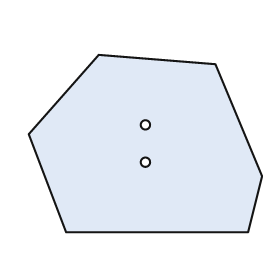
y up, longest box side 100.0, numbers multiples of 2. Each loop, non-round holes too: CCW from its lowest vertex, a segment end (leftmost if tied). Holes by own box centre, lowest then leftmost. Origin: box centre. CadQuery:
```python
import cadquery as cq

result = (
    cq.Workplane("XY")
    .moveTo(-34.0, -38.0)
    .lineTo(44.0, -38.0)
    .lineTo(50.0, -14.0)
    .lineTo(30.0, 34.0)
    .lineTo(-20.0, 38.0)
    .lineTo(-50.0, 4.0)
    .close()
    .moveTo(0.0, -8.0)
    .circle(2.0)
    .moveTo(0.0, 8.0)
    .circle(2.0)
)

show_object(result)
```